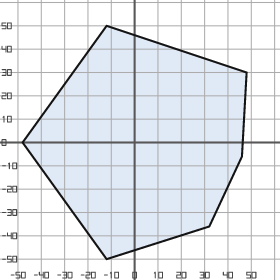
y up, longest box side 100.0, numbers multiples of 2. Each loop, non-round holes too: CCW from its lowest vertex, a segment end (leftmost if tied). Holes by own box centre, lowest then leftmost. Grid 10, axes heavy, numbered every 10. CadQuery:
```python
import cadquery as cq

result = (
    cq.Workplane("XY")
    .moveTo(-12.0, -50.0)
    .lineTo(32.0, -36.0)
    .lineTo(46.0, -6.0)
    .lineTo(48.0, 30.0)
    .lineTo(-12.0, 50.0)
    .lineTo(-48.0, 0.0)
    .close()
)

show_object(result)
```